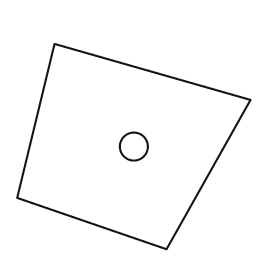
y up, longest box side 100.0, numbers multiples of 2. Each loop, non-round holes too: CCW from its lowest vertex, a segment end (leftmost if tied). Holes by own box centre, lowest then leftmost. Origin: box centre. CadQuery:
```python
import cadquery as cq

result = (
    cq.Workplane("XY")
    .moveTo(14.0, -44.0)
    .lineTo(50.0, 20.0)
    .lineTo(-34.0, 44.0)
    .lineTo(-50.0, -22.0)
    .close()
    .moveTo(0.0, 0.0)
    .circle(6.0)
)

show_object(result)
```